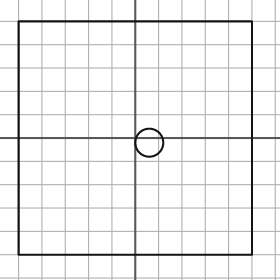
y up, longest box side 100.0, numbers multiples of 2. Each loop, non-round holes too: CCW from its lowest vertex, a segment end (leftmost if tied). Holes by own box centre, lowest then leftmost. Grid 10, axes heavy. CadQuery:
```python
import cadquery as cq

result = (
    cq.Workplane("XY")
    .moveTo(-50.0, -50.0)
    .lineTo(50.0, -50.0)
    .lineTo(50.0, 50.0)
    .lineTo(-50.0, 50.0)
    .close()
    .moveTo(6.0, -2.0)
    .circle(6.0)
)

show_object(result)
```